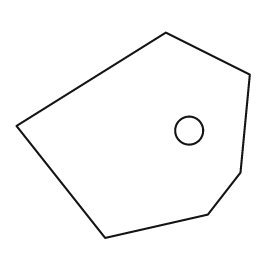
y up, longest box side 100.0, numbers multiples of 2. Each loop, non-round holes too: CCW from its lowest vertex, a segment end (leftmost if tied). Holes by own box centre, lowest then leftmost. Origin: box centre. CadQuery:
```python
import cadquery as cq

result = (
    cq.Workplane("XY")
    .moveTo(-12.0, -44.0)
    .lineTo(32.0, -34.0)
    .lineTo(46.0, -16.0)
    .lineTo(50.0, 26.0)
    .lineTo(14.0, 44.0)
    .lineTo(-50.0, 4.0)
    .close()
    .moveTo(24.0, 2.0)
    .circle(6.0)
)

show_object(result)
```